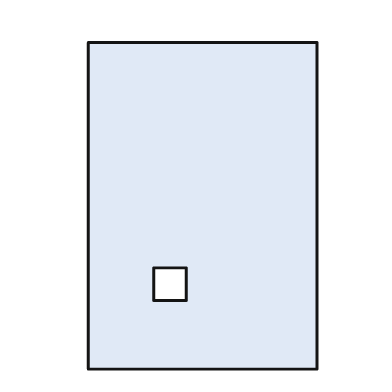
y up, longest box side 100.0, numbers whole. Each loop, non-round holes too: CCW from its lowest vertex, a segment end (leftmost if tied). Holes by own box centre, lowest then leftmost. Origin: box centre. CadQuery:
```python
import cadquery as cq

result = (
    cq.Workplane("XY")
    .moveTo(-35.0, -50.0)
    .lineTo(35.0, -50.0)
    .lineTo(35.0, 50.0)
    .lineTo(-35.0, 50.0)
    .close()
    .moveTo(-15.0, -29.0)
    .lineTo(-5.0, -29.0)
    .lineTo(-5.0, -19.0)
    .lineTo(-15.0, -19.0)
    .close()
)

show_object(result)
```